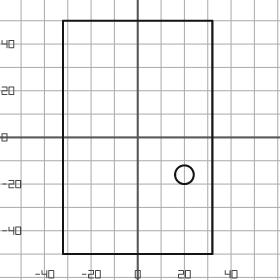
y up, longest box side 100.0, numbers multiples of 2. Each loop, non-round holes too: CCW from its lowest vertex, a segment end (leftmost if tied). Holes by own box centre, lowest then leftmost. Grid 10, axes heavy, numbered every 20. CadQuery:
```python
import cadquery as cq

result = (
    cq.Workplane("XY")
    .moveTo(-32.0, -50.0)
    .lineTo(32.0, -50.0)
    .lineTo(32.0, 50.0)
    .lineTo(-32.0, 50.0)
    .close()
    .moveTo(20.0, -16.0)
    .circle(4.0)
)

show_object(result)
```